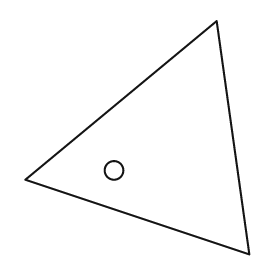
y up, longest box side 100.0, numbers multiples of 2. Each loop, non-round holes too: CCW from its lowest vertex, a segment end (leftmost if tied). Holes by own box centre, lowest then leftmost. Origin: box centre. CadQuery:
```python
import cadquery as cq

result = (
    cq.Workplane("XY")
    .moveTo(48.0, -50.0)
    .lineTo(34.0, 50.0)
    .lineTo(-48.0, -18.0)
    .close()
    .moveTo(-10.0, -14.0)
    .circle(4.0)
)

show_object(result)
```